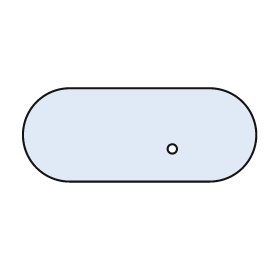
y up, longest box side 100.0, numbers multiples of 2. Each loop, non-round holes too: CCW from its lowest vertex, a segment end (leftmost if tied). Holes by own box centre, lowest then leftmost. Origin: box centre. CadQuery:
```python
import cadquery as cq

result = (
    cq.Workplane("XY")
    .moveTo(-30.0, -20.0)
    .lineTo(30.0, -20.0)
    .threePointArc((50.0, 0.0), (30.0, 20.0))
    .lineTo(-30.0, 20.0)
    .threePointArc((-50.0, 0.0), (-30.0, -20.0))
    .close()
    .moveTo(14.0, -6.0)
    .circle(2.0)
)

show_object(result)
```